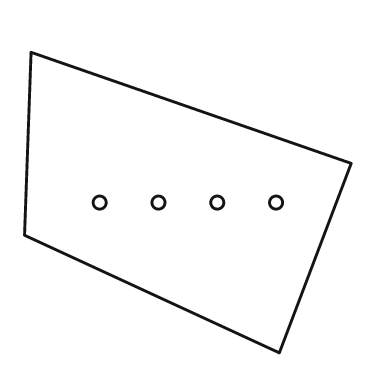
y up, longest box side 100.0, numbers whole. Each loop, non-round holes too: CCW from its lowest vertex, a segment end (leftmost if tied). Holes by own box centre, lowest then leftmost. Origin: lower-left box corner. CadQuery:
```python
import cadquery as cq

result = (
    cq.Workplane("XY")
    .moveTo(78.0, 0.0)
    .lineTo(100.0, 58.0)
    .lineTo(2.0, 92.0)
    .lineTo(0.0, 36.0)
    .close()
    .moveTo(23.0, 46.0)
    .circle(2.0)
    .moveTo(41.0, 46.0)
    .circle(2.0)
    .moveTo(59.0, 46.0)
    .circle(2.0)
    .moveTo(77.0, 46.0)
    .circle(2.0)
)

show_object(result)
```